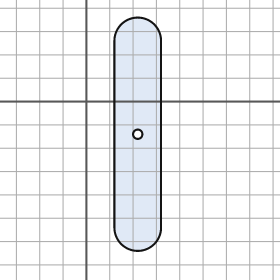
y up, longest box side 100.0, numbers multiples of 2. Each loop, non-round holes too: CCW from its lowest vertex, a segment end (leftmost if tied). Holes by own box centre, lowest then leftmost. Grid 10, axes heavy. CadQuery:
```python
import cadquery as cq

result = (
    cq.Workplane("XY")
    .moveTo(12.0, -54.0)
    .threePointArc((22.0, -64.0), (32.0, -54.0))
    .lineTo(32.0, 26.0)
    .threePointArc((22.0, 36.0), (12.0, 26.0))
    .close()
    .moveTo(22.0, -14.0)
    .circle(2.0)
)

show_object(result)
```